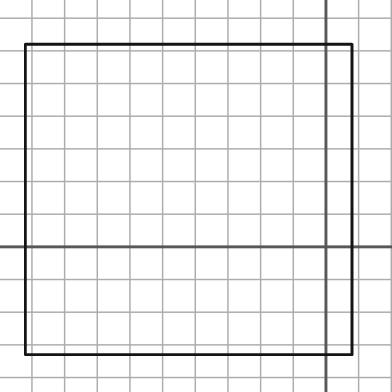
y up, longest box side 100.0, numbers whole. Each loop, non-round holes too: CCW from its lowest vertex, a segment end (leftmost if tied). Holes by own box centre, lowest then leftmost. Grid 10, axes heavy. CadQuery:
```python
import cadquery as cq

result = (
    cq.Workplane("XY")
    .moveTo(-92.0, -33.0)
    .lineTo(8.0, -33.0)
    .lineTo(8.0, 62.0)
    .lineTo(-92.0, 62.0)
    .close()
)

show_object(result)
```